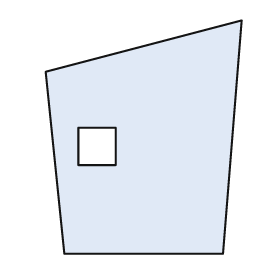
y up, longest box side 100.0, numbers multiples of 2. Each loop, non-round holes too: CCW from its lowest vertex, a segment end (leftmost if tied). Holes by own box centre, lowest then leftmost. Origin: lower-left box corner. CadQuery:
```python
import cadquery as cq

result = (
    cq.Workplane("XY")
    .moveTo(8.0, 0.0)
    .lineTo(76.0, 0.0)
    .lineTo(84.0, 100.0)
    .lineTo(0.0, 78.0)
    .close()
    .moveTo(14.0, 38.0)
    .lineTo(30.0, 38.0)
    .lineTo(30.0, 54.0)
    .lineTo(14.0, 54.0)
    .close()
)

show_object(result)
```